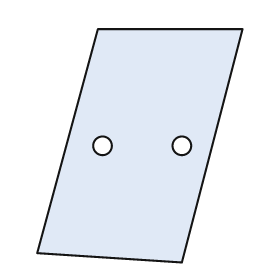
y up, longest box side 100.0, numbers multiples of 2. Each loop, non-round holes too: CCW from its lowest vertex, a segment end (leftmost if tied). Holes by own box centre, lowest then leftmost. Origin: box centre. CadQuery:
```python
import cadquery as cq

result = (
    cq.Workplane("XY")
    .moveTo(18.0, -50.0)
    .lineTo(44.0, 50.0)
    .lineTo(-18.0, 50.0)
    .lineTo(-44.0, -46.0)
    .close()
    .moveTo(-16.0, 0.0)
    .circle(4.0)
    .moveTo(18.0, 0.0)
    .circle(4.0)
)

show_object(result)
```